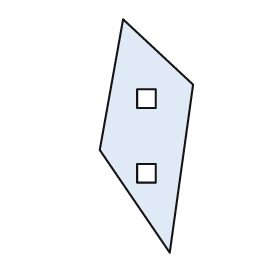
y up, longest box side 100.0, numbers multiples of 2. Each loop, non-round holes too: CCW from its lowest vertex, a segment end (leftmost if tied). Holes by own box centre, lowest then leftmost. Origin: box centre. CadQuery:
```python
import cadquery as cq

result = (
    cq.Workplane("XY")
    .moveTo(10.0, -50.0)
    .lineTo(20.0, 22.0)
    .lineTo(-10.0, 50.0)
    .lineTo(-20.0, -6.0)
    .close()
    .moveTo(-4.0, -20.0)
    .lineTo(4.0, -20.0)
    .lineTo(4.0, -12.0)
    .lineTo(-4.0, -12.0)
    .close()
    .moveTo(-4.0, 12.0)
    .lineTo(4.0, 12.0)
    .lineTo(4.0, 20.0)
    .lineTo(-4.0, 20.0)
    .close()
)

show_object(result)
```